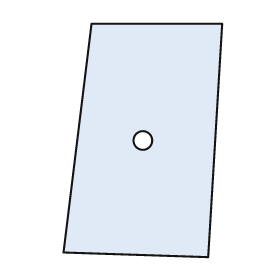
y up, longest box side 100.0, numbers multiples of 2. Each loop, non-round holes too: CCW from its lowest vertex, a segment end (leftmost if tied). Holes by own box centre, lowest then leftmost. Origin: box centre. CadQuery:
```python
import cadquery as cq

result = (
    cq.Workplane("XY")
    .moveTo(28.0, -50.0)
    .lineTo(34.0, 50.0)
    .lineTo(-22.0, 50.0)
    .lineTo(-34.0, -48.0)
    .close()
    .moveTo(0.0, 0.0)
    .circle(4.0)
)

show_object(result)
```